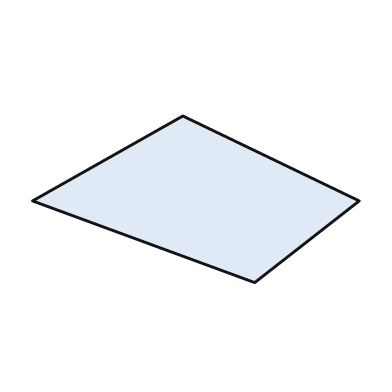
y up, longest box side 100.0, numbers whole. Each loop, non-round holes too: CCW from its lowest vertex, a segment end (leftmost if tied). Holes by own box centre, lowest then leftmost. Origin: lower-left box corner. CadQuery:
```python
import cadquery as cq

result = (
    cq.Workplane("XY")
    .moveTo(68.0, 0.0)
    .lineTo(100.0, 25.0)
    .lineTo(46.0, 51.0)
    .lineTo(0.0, 25.0)
    .close()
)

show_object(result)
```